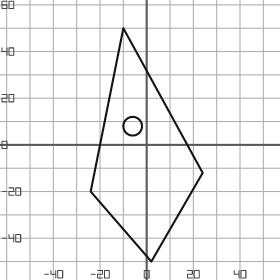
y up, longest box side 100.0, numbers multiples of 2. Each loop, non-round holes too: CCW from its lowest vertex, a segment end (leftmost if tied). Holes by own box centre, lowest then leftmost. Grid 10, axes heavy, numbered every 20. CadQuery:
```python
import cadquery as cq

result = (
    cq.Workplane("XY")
    .moveTo(2.0, -50.0)
    .lineTo(24.0, -12.0)
    .lineTo(-10.0, 50.0)
    .lineTo(-24.0, -20.0)
    .close()
    .moveTo(-6.0, 8.0)
    .circle(4.0)
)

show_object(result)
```